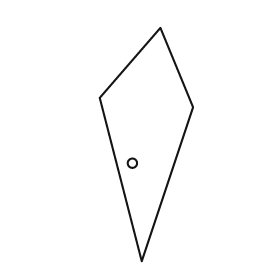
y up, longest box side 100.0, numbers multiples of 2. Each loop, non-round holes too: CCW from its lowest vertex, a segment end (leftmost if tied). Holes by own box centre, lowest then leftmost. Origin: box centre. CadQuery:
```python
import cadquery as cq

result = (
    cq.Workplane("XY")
    .moveTo(-2.0, -50.0)
    .lineTo(20.0, 16.0)
    .lineTo(6.0, 50.0)
    .lineTo(-20.0, 20.0)
    .close()
    .moveTo(-6.0, -8.0)
    .circle(2.0)
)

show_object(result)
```